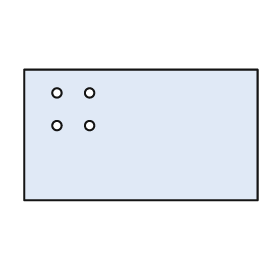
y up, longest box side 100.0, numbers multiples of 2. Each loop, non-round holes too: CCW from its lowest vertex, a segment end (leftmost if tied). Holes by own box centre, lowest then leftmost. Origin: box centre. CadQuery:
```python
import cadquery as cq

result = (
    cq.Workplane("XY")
    .moveTo(-50.0, -28.0)
    .lineTo(50.0, -28.0)
    .lineTo(50.0, 28.0)
    .lineTo(-50.0, 28.0)
    .close()
    .moveTo(-36.0, 4.0)
    .circle(2.0)
    .moveTo(-22.0, 4.0)
    .circle(2.0)
    .moveTo(-36.0, 18.0)
    .circle(2.0)
    .moveTo(-22.0, 18.0)
    .circle(2.0)
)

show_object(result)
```